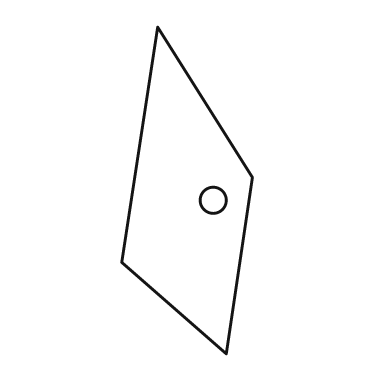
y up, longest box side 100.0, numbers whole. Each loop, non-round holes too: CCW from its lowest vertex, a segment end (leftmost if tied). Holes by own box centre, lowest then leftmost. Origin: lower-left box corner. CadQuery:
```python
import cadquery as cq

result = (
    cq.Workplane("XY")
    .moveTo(32.0, 0.0)
    .lineTo(40.0, 54.0)
    .lineTo(11.0, 100.0)
    .lineTo(0.0, 28.0)
    .close()
    .moveTo(28.0, 47.0)
    .circle(4.0)
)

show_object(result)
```